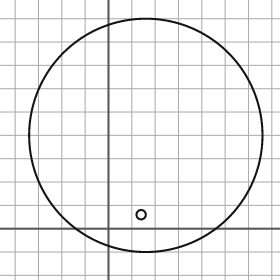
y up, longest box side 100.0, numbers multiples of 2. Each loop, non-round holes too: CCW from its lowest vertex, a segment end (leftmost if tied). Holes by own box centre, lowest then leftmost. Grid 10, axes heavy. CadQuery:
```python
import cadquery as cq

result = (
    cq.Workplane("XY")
    .moveTo(16.0, 40.0)
    .circle(50.0)
    .moveTo(14.0, 6.0)
    .circle(2.0)
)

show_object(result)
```